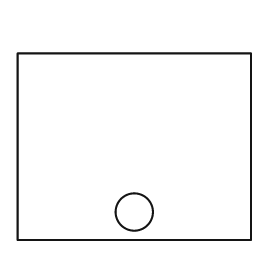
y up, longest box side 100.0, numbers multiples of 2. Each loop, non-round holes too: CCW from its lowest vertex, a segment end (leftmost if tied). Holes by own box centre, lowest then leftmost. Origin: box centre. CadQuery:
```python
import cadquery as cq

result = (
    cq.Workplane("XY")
    .moveTo(-50.0, -40.0)
    .lineTo(50.0, -40.0)
    .lineTo(50.0, 40.0)
    .lineTo(-50.0, 40.0)
    .close()
    .moveTo(0.0, -28.0)
    .circle(8.0)
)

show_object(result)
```